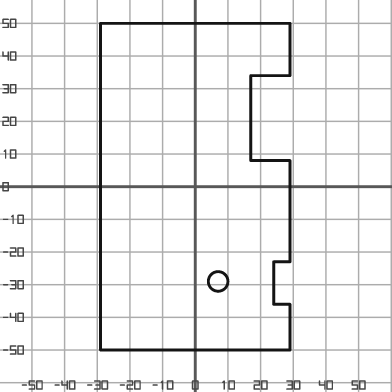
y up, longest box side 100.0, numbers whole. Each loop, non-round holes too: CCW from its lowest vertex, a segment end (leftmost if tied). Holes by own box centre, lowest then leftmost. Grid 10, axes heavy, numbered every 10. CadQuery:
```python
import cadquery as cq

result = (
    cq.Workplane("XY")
    .moveTo(-29.0, -50.0)
    .lineTo(29.0, -50.0)
    .lineTo(29.0, -36.0)
    .lineTo(24.0, -36.0)
    .lineTo(24.0, -23.0)
    .lineTo(29.0, -23.0)
    .lineTo(29.0, 8.0)
    .lineTo(17.0, 8.0)
    .lineTo(17.0, 34.0)
    .lineTo(29.0, 34.0)
    .lineTo(29.0, 50.0)
    .lineTo(-29.0, 50.0)
    .close()
    .moveTo(7.0, -29.0)
    .circle(3.0)
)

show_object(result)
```